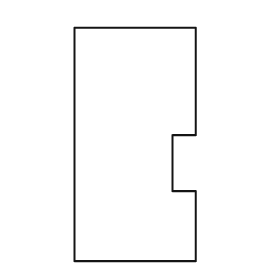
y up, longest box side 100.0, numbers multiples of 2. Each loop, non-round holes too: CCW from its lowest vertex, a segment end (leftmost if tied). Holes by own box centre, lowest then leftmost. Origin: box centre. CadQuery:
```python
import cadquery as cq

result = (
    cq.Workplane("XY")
    .moveTo(-26.0, -50.0)
    .lineTo(26.0, -50.0)
    .lineTo(26.0, -20.0)
    .lineTo(16.0, -20.0)
    .lineTo(16.0, 4.0)
    .lineTo(26.0, 4.0)
    .lineTo(26.0, 50.0)
    .lineTo(-26.0, 50.0)
    .close()
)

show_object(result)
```